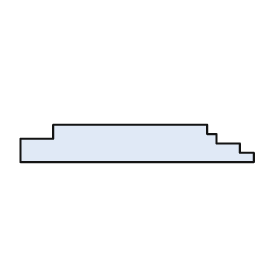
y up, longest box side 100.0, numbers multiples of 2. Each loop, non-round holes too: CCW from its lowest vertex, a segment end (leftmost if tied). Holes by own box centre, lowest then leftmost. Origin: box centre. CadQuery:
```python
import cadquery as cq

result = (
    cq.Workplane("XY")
    .moveTo(-50.0, -8.0)
    .lineTo(50.0, -8.0)
    .lineTo(50.0, -4.0)
    .lineTo(44.0, -4.0)
    .lineTo(44.0, 0.0)
    .lineTo(34.0, 0.0)
    .lineTo(34.0, 4.0)
    .lineTo(30.0, 4.0)
    .lineTo(30.0, 8.0)
    .lineTo(-36.0, 8.0)
    .lineTo(-36.0, 2.0)
    .lineTo(-50.0, 2.0)
    .close()
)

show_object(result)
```